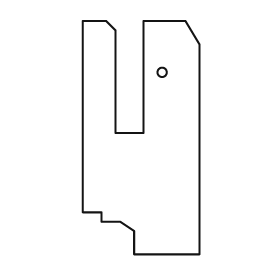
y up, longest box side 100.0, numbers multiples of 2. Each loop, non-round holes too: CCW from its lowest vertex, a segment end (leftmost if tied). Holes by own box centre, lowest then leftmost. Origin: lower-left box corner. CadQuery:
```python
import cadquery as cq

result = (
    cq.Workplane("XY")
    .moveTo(22.0, 0.0)
    .lineTo(50.0, 0.0)
    .lineTo(50.0, 90.0)
    .lineTo(44.0, 100.0)
    .lineTo(26.0, 100.0)
    .lineTo(26.0, 52.0)
    .lineTo(14.0, 52.0)
    .lineTo(14.0, 96.0)
    .lineTo(10.0, 100.0)
    .lineTo(0.0, 100.0)
    .lineTo(0.0, 18.0)
    .lineTo(8.0, 18.0)
    .lineTo(8.0, 14.0)
    .lineTo(16.0, 14.0)
    .lineTo(22.0, 10.0)
    .close()
    .moveTo(34.0, 78.0)
    .circle(2.0)
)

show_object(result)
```